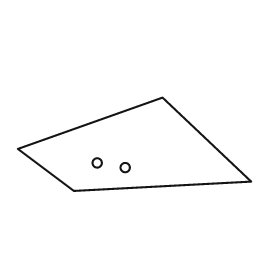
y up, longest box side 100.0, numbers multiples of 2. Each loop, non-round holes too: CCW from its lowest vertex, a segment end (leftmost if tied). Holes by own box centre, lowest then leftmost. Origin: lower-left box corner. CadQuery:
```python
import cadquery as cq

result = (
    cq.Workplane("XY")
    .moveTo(24.0, 0.0)
    .lineTo(100.0, 4.0)
    .lineTo(62.0, 40.0)
    .lineTo(0.0, 18.0)
    .close()
    .moveTo(46.0, 10.0)
    .circle(2.0)
    .moveTo(34.0, 12.0)
    .circle(2.0)
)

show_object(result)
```